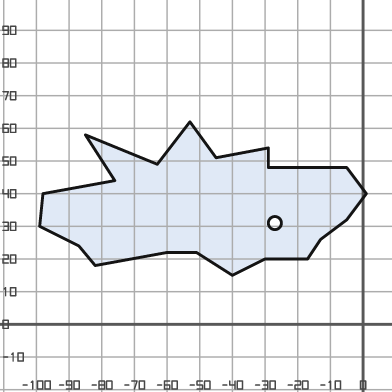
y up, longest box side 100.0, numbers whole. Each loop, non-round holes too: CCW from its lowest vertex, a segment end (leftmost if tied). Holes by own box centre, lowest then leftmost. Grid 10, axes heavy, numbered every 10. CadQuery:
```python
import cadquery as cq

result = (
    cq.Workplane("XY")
    .moveTo(-40.0, 15.0)
    .lineTo(-30.0, 20.0)
    .lineTo(-17.0, 20.0)
    .lineTo(-13.0, 26.0)
    .lineTo(-5.0, 32.0)
    .lineTo(1.0, 40.0)
    .lineTo(-5.0, 48.0)
    .lineTo(-29.0, 48.0)
    .lineTo(-29.0, 54.0)
    .lineTo(-45.0, 51.0)
    .lineTo(-53.0, 62.0)
    .lineTo(-63.0, 49.0)
    .lineTo(-85.0, 58.0)
    .lineTo(-76.0, 44.0)
    .lineTo(-98.0, 40.0)
    .lineTo(-99.0, 30.0)
    .lineTo(-87.0, 24.0)
    .lineTo(-82.0, 18.0)
    .lineTo(-60.0, 22.0)
    .lineTo(-51.0, 22.0)
    .close()
    .moveTo(-27.0, 31.0)
    .circle(2.0)
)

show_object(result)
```